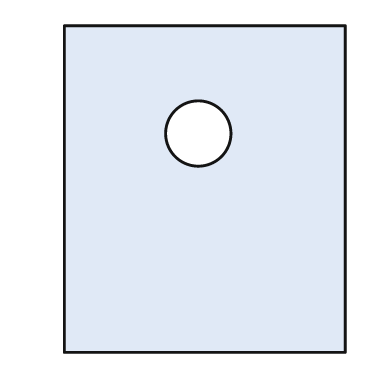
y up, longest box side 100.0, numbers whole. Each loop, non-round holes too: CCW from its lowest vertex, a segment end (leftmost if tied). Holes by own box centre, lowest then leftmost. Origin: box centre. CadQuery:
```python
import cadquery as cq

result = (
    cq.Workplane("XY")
    .moveTo(-43.0, -50.0)
    .lineTo(43.0, -50.0)
    .lineTo(43.0, 50.0)
    .lineTo(-43.0, 50.0)
    .close()
    .moveTo(-2.0, 17.0)
    .circle(10.0)
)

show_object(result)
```